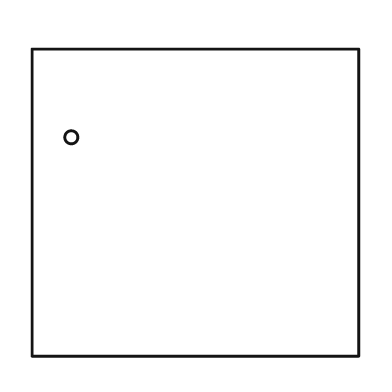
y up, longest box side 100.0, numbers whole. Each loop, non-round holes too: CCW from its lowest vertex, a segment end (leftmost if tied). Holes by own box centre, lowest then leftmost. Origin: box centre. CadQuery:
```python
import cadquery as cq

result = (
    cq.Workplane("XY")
    .moveTo(-50.0, -47.0)
    .lineTo(50.0, -47.0)
    .lineTo(50.0, 47.0)
    .lineTo(-50.0, 47.0)
    .close()
    .moveTo(-38.0, 20.0)
    .circle(2.0)
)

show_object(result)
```